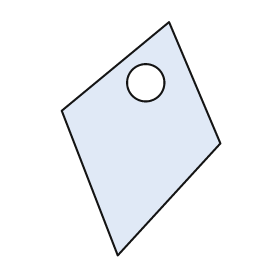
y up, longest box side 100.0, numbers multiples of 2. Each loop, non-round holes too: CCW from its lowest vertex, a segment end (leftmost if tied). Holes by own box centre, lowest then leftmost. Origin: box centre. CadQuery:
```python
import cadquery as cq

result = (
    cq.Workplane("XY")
    .moveTo(-10.0, -50.0)
    .lineTo(34.0, -2.0)
    .lineTo(12.0, 50.0)
    .lineTo(-34.0, 12.0)
    .close()
    .moveTo(2.0, 24.0)
    .circle(8.0)
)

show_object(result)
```